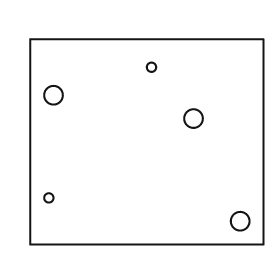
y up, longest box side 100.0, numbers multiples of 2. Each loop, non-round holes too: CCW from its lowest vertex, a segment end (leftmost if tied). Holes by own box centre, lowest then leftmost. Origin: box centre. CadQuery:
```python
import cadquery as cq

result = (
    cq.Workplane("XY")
    .moveTo(-50.0, -44.0)
    .lineTo(50.0, -44.0)
    .lineTo(50.0, 44.0)
    .lineTo(-50.0, 44.0)
    .close()
    .moveTo(40.0, -34.0)
    .circle(4.0)
    .moveTo(-42.0, -24.0)
    .circle(2.0)
    .moveTo(20.0, 10.0)
    .circle(4.0)
    .moveTo(-40.0, 20.0)
    .circle(4.0)
    .moveTo(2.0, 32.0)
    .circle(2.0)
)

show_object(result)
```